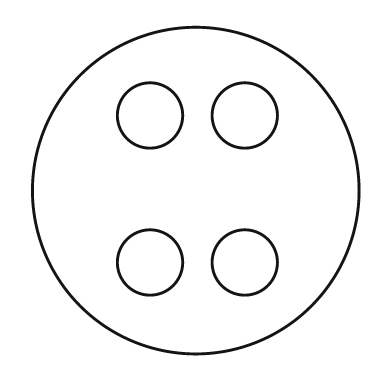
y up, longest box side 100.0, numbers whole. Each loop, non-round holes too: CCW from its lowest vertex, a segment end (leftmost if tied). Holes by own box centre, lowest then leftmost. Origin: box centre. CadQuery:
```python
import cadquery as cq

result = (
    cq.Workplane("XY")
    .moveTo(0.0, 0.0)
    .circle(50.0)
    .moveTo(-14.0, -22.0)
    .circle(10.0)
    .moveTo(15.0, -22.0)
    .circle(10.0)
    .moveTo(-14.0, 23.0)
    .circle(10.0)
    .moveTo(15.0, 23.0)
    .circle(10.0)
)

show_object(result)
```